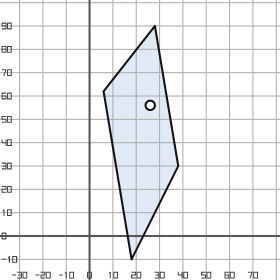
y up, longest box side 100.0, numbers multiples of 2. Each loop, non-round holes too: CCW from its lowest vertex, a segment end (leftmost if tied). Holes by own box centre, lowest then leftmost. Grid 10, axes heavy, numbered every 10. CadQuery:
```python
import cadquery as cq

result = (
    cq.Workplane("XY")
    .moveTo(18.0, -10.0)
    .lineTo(38.0, 30.0)
    .lineTo(28.0, 90.0)
    .lineTo(6.0, 62.0)
    .close()
    .moveTo(26.0, 56.0)
    .circle(2.0)
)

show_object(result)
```